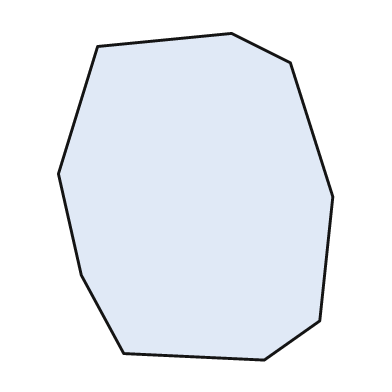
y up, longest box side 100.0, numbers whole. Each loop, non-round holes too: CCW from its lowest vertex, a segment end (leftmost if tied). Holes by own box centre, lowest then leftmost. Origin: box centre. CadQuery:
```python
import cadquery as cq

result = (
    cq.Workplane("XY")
    .moveTo(21.0, -50.0)
    .lineTo(38.0, -38.0)
    .lineTo(42.0, 0.0)
    .lineTo(29.0, 41.0)
    .lineTo(11.0, 50.0)
    .lineTo(-30.0, 46.0)
    .lineTo(-42.0, 7.0)
    .lineTo(-35.0, -24.0)
    .lineTo(-22.0, -48.0)
    .close()
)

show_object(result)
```